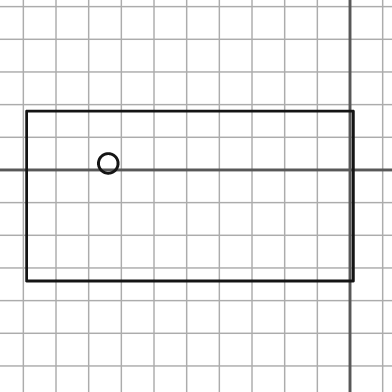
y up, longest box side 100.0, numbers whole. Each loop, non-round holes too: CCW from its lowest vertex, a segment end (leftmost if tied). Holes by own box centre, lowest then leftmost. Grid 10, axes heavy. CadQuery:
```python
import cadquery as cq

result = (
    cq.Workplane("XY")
    .moveTo(-99.0, -34.0)
    .lineTo(1.0, -34.0)
    .lineTo(1.0, 18.0)
    .lineTo(-99.0, 18.0)
    .close()
    .moveTo(-74.0, 2.0)
    .circle(3.0)
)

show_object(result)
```